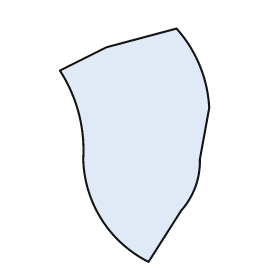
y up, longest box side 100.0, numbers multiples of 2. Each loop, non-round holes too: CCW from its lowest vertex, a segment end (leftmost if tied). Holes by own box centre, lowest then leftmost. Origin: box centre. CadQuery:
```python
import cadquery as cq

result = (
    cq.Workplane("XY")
    .moveTo(6.0, -50.0)
    .lineTo(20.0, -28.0)
    .threePointArc((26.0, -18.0), (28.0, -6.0))
    .lineTo(32.0, 16.0)
    .threePointArc((28.0, 34.0), (18.0, 50.0))
    .lineTo(-12.0, 42.0)
    .lineTo(-32.0, 32.0)
    .threePointArc((-24.0, 14.0), (-22.0, -6.0))
    .threePointArc((-14.0, -32.0), (6.0, -50.0))
    .close()
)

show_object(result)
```